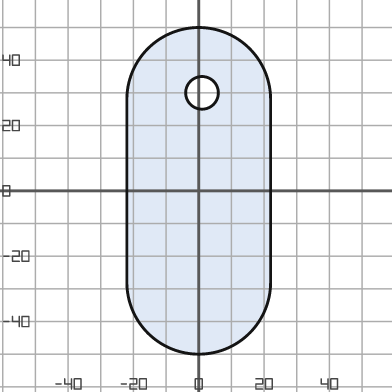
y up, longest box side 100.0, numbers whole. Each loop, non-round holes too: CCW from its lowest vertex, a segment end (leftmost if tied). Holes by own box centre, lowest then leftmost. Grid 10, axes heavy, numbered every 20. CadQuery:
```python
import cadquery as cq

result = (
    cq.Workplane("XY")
    .moveTo(-22.0, -28.0)
    .threePointArc((0.0, -50.0), (22.0, -28.0))
    .lineTo(22.0, 28.0)
    .threePointArc((0.0, 50.0), (-22.0, 28.0))
    .close()
    .moveTo(1.0, 30.0)
    .circle(5.0)
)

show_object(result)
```